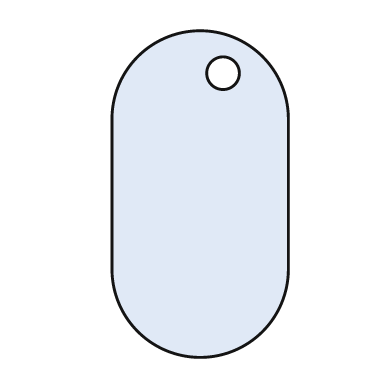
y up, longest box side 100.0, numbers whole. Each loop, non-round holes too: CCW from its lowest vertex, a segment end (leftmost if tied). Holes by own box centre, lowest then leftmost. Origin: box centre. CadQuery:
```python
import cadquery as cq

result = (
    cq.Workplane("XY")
    .moveTo(-27.0, -23.0)
    .threePointArc((0.0, -50.0), (27.0, -23.0))
    .lineTo(27.0, 23.0)
    .threePointArc((0.0, 50.0), (-27.0, 23.0))
    .close()
    .moveTo(7.0, 37.0)
    .circle(5.0)
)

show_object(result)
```